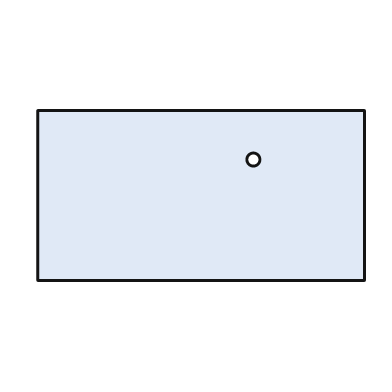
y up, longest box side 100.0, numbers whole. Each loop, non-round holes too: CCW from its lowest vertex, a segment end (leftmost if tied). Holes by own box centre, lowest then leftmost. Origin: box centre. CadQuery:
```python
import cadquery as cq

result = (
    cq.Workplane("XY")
    .moveTo(-50.0, -26.0)
    .lineTo(50.0, -26.0)
    .lineTo(50.0, 26.0)
    .lineTo(-50.0, 26.0)
    .close()
    .moveTo(16.0, 11.0)
    .circle(2.0)
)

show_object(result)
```